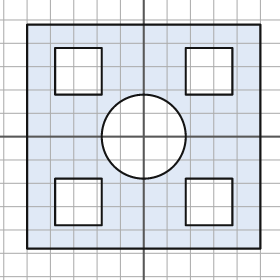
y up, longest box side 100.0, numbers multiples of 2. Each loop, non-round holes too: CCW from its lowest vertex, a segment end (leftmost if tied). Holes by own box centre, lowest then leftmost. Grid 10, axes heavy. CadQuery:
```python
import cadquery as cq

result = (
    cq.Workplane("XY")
    .moveTo(-50.0, -48.0)
    .lineTo(50.0, -48.0)
    .lineTo(50.0, 48.0)
    .lineTo(-50.0, 48.0)
    .close()
    .moveTo(-38.0, -38.0)
    .lineTo(-18.0, -38.0)
    .lineTo(-18.0, -18.0)
    .lineTo(-38.0, -18.0)
    .close()
    .moveTo(18.0, -38.0)
    .lineTo(38.0, -38.0)
    .lineTo(38.0, -18.0)
    .lineTo(18.0, -18.0)
    .close()
    .moveTo(0.0, 0.0)
    .circle(18.0)
    .moveTo(-38.0, 18.0)
    .lineTo(-18.0, 18.0)
    .lineTo(-18.0, 38.0)
    .lineTo(-38.0, 38.0)
    .close()
    .moveTo(18.0, 18.0)
    .lineTo(38.0, 18.0)
    .lineTo(38.0, 38.0)
    .lineTo(18.0, 38.0)
    .close()
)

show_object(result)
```